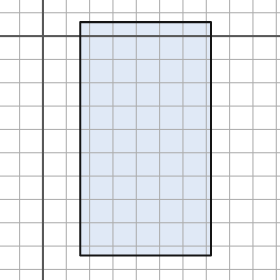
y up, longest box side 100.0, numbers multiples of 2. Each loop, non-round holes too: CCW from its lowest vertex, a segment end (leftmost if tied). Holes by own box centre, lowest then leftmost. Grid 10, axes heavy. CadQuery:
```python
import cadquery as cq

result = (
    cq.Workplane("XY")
    .moveTo(16.0, -94.0)
    .lineTo(72.0, -94.0)
    .lineTo(72.0, 6.0)
    .lineTo(16.0, 6.0)
    .close()
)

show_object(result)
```